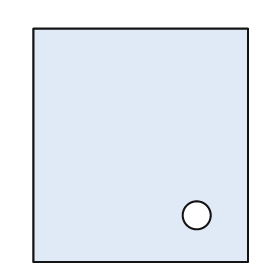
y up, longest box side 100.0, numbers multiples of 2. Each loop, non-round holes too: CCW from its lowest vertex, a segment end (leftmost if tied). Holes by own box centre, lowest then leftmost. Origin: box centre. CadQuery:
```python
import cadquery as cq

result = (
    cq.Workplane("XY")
    .moveTo(-46.0, -50.0)
    .lineTo(46.0, -50.0)
    .lineTo(46.0, 50.0)
    .lineTo(-46.0, 50.0)
    .close()
    .moveTo(24.0, -30.0)
    .circle(6.0)
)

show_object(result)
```